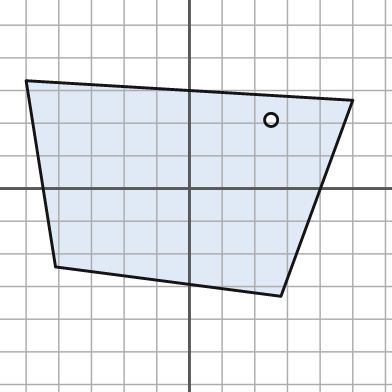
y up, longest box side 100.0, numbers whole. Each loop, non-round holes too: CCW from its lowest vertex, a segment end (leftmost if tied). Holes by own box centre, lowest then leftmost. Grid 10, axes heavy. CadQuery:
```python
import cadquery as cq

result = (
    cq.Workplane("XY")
    .moveTo(28.0, -33.0)
    .lineTo(50.0, 27.0)
    .lineTo(-50.0, 33.0)
    .lineTo(-41.0, -24.0)
    .close()
    .moveTo(25.0, 21.0)
    .circle(2.0)
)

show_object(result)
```